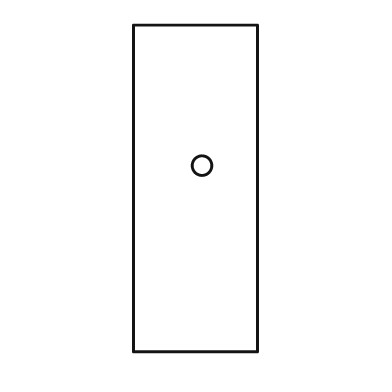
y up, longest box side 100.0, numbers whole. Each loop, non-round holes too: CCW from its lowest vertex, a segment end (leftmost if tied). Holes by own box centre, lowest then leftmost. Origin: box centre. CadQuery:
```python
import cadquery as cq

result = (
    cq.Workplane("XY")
    .moveTo(-19.0, -50.0)
    .lineTo(19.0, -50.0)
    .lineTo(19.0, 50.0)
    .lineTo(-19.0, 50.0)
    .close()
    .moveTo(2.0, 7.0)
    .circle(3.0)
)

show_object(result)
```